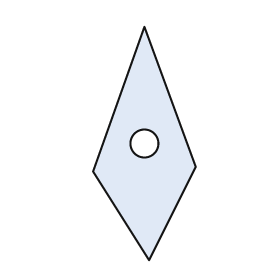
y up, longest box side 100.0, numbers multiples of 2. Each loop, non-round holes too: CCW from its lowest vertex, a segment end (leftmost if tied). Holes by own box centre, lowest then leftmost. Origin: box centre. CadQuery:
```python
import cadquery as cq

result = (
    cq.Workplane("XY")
    .moveTo(2.0, -50.0)
    .lineTo(22.0, -10.0)
    .lineTo(0.0, 50.0)
    .lineTo(-22.0, -12.0)
    .close()
    .moveTo(0.0, 0.0)
    .circle(6.0)
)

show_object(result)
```